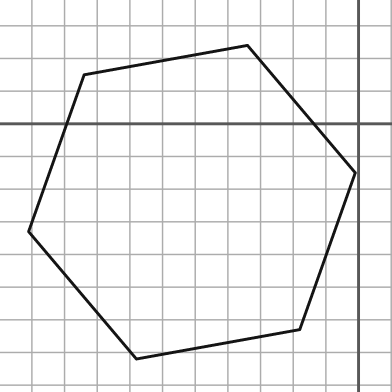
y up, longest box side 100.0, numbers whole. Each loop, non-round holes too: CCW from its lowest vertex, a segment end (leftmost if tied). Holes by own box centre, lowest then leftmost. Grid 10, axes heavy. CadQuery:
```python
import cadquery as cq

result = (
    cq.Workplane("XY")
    .moveTo(-68.0, -72.0)
    .lineTo(-18.0, -63.0)
    .lineTo(-1.0, -15.0)
    .lineTo(-34.0, 24.0)
    .lineTo(-84.0, 15.0)
    .lineTo(-101.0, -33.0)
    .close()
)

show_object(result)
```